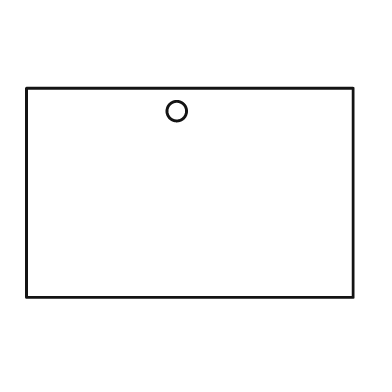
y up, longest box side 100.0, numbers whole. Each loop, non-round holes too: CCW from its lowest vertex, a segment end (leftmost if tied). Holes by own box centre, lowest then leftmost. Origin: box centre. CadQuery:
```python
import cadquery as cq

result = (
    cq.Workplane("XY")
    .moveTo(-50.0, -32.0)
    .lineTo(50.0, -32.0)
    .lineTo(50.0, 32.0)
    .lineTo(-50.0, 32.0)
    .close()
    .moveTo(-4.0, 25.0)
    .circle(3.0)
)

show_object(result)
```